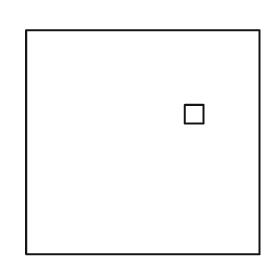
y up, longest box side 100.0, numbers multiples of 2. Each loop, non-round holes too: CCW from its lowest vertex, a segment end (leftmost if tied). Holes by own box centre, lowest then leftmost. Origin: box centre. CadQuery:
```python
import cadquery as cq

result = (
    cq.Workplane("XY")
    .moveTo(-50.0, -48.0)
    .lineTo(50.0, -48.0)
    .lineTo(50.0, 48.0)
    .lineTo(-50.0, 48.0)
    .close()
    .moveTo(18.0, 8.0)
    .lineTo(26.0, 8.0)
    .lineTo(26.0, 16.0)
    .lineTo(18.0, 16.0)
    .close()
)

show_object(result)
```